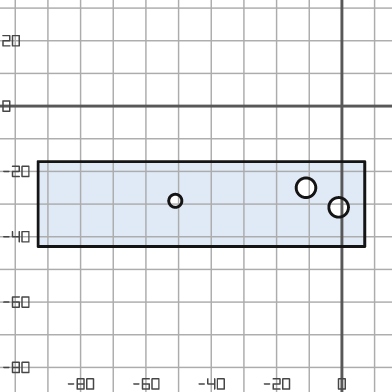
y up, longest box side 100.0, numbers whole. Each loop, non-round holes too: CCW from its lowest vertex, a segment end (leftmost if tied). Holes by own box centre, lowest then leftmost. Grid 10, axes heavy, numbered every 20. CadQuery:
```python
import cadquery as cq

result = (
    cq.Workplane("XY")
    .moveTo(-93.0, -43.0)
    .lineTo(7.0, -43.0)
    .lineTo(7.0, -17.0)
    .lineTo(-93.0, -17.0)
    .close()
    .moveTo(-1.0, -31.0)
    .circle(3.0)
    .moveTo(-51.0, -29.0)
    .circle(2.0)
    .moveTo(-11.0, -25.0)
    .circle(3.0)
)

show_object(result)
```